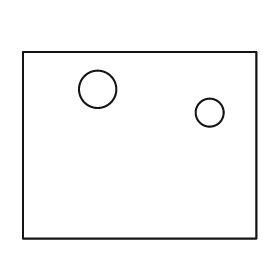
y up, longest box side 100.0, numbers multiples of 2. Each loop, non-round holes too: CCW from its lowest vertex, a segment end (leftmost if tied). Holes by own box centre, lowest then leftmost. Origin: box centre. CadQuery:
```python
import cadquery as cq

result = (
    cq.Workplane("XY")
    .moveTo(-50.0, -40.0)
    .lineTo(50.0, -40.0)
    .lineTo(50.0, 40.0)
    .lineTo(-50.0, 40.0)
    .close()
    .moveTo(30.0, 14.0)
    .circle(6.0)
    .moveTo(-18.0, 24.0)
    .circle(8.0)
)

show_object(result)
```